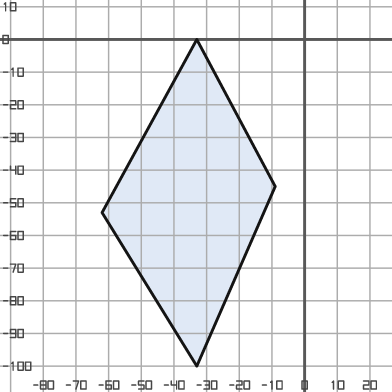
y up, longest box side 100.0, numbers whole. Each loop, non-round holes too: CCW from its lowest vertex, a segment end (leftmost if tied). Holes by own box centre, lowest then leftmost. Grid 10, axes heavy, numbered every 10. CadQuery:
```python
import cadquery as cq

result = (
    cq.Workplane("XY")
    .moveTo(-33.0, -100.0)
    .lineTo(-9.0, -45.0)
    .lineTo(-33.0, 0.0)
    .lineTo(-62.0, -53.0)
    .close()
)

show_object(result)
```